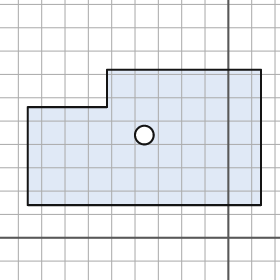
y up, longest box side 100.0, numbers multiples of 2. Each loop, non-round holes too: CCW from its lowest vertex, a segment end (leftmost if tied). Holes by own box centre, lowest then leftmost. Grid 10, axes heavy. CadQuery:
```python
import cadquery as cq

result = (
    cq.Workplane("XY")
    .moveTo(-86.0, 14.0)
    .lineTo(14.0, 14.0)
    .lineTo(14.0, 72.0)
    .lineTo(-52.0, 72.0)
    .lineTo(-52.0, 56.0)
    .lineTo(-86.0, 56.0)
    .close()
    .moveTo(-36.0, 44.0)
    .circle(4.0)
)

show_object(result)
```